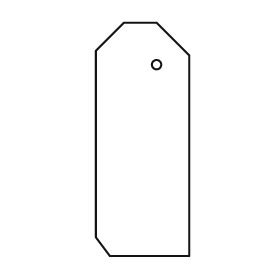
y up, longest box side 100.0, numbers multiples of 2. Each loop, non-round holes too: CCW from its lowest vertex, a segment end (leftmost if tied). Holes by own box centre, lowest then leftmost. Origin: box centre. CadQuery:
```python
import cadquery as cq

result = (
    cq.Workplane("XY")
    .moveTo(-14.0, -50.0)
    .lineTo(20.0, -50.0)
    .lineTo(20.0, 36.0)
    .lineTo(6.0, 50.0)
    .lineTo(-8.0, 50.0)
    .lineTo(-20.0, 38.0)
    .lineTo(-20.0, -42.0)
    .close()
    .moveTo(6.0, 32.0)
    .circle(2.0)
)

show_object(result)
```